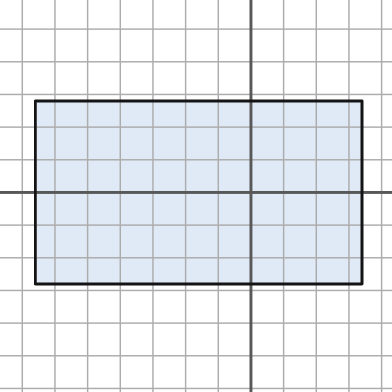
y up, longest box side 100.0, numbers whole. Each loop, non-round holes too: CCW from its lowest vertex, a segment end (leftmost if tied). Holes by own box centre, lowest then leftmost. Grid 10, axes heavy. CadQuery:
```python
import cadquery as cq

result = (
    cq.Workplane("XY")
    .moveTo(-66.0, -28.0)
    .lineTo(34.0, -28.0)
    .lineTo(34.0, 28.0)
    .lineTo(-66.0, 28.0)
    .close()
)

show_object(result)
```